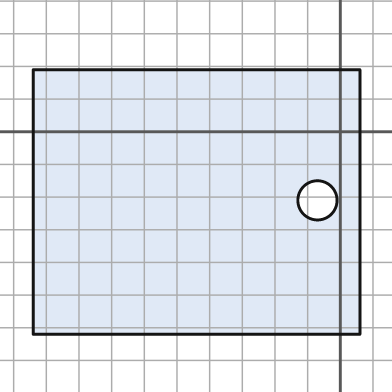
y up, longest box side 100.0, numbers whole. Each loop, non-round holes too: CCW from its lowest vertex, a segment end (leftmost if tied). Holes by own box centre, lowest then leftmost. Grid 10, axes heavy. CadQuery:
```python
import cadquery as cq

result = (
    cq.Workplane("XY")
    .moveTo(-94.0, -62.0)
    .lineTo(6.0, -62.0)
    .lineTo(6.0, 19.0)
    .lineTo(-94.0, 19.0)
    .close()
    .moveTo(-7.0, -21.0)
    .circle(6.0)
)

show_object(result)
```